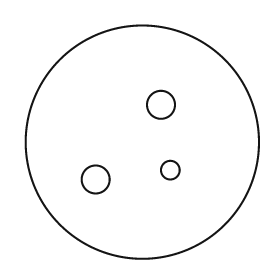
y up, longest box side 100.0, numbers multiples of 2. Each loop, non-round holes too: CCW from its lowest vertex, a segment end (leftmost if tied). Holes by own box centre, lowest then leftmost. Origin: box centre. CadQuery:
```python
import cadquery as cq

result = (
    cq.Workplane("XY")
    .moveTo(0.0, 0.0)
    .circle(50.0)
    .moveTo(-20.0, -16.0)
    .circle(6.0)
    .moveTo(12.0, -12.0)
    .circle(4.0)
    .moveTo(8.0, 16.0)
    .circle(6.0)
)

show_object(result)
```